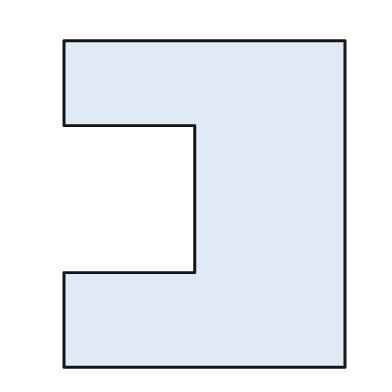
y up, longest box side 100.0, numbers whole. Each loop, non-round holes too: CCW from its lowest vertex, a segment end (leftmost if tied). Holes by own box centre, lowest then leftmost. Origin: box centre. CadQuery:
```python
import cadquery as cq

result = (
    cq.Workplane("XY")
    .moveTo(-43.0, -50.0)
    .lineTo(43.0, -50.0)
    .lineTo(43.0, 50.0)
    .lineTo(-43.0, 50.0)
    .lineTo(-43.0, 24.0)
    .lineTo(-3.0, 24.0)
    .lineTo(-3.0, -21.0)
    .lineTo(-43.0, -21.0)
    .close()
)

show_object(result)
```